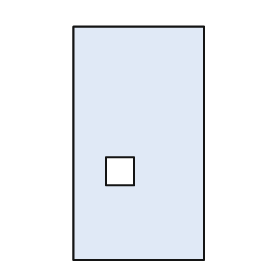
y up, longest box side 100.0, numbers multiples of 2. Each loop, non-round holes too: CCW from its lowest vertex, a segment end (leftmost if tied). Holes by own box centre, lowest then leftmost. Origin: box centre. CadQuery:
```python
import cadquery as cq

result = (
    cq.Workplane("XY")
    .moveTo(-28.0, -50.0)
    .lineTo(28.0, -50.0)
    .lineTo(28.0, 50.0)
    .lineTo(-28.0, 50.0)
    .close()
    .moveTo(-14.0, -18.0)
    .lineTo(-2.0, -18.0)
    .lineTo(-2.0, -6.0)
    .lineTo(-14.0, -6.0)
    .close()
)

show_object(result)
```